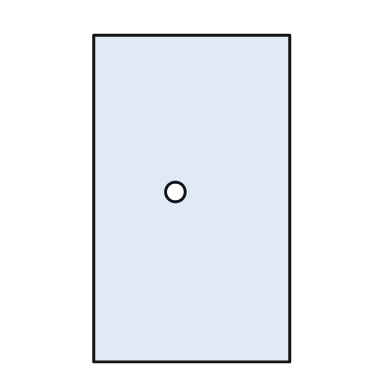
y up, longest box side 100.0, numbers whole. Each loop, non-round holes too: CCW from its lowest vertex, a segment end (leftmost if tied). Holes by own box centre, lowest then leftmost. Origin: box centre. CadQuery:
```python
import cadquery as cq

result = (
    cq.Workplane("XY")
    .moveTo(-30.0, -50.0)
    .lineTo(30.0, -50.0)
    .lineTo(30.0, 50.0)
    .lineTo(-30.0, 50.0)
    .close()
    .moveTo(-5.0, 2.0)
    .circle(3.0)
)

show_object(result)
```